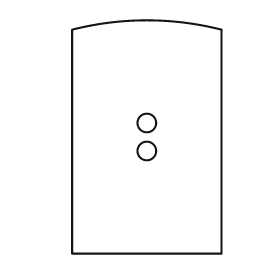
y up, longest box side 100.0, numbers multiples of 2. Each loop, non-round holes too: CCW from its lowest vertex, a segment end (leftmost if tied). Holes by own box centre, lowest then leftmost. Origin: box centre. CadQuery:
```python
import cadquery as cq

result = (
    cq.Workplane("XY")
    .moveTo(-32.0, -50.0)
    .lineTo(32.0, -50.0)
    .lineTo(32.0, 46.0)
    .threePointArc((0.0, 50.0), (-32.0, 46.0))
    .close()
    .moveTo(0.0, -6.0)
    .circle(4.0)
    .moveTo(0.0, 6.0)
    .circle(4.0)
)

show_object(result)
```